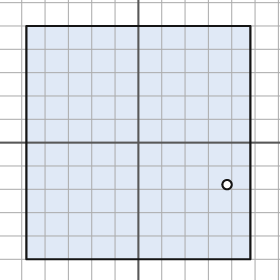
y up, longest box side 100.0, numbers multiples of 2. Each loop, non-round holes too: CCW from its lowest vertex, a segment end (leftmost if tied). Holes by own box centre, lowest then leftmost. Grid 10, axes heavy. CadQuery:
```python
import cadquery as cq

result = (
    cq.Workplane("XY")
    .moveTo(-48.0, -50.0)
    .lineTo(48.0, -50.0)
    .lineTo(48.0, 50.0)
    .lineTo(-48.0, 50.0)
    .close()
    .moveTo(38.0, -18.0)
    .circle(2.0)
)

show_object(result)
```